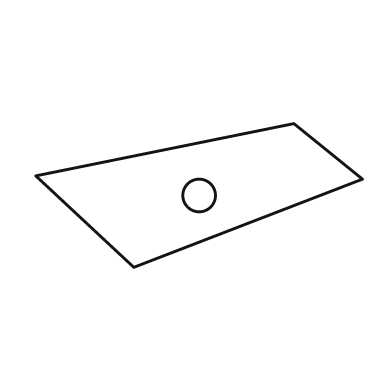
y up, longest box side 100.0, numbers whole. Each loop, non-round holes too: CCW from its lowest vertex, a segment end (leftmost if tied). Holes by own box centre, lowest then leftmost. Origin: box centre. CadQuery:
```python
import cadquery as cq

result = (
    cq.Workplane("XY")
    .moveTo(-20.0, -22.0)
    .lineTo(50.0, 5.0)
    .lineTo(29.0, 22.0)
    .lineTo(-50.0, 6.0)
    .close()
    .moveTo(0.0, 0.0)
    .circle(5.0)
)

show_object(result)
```